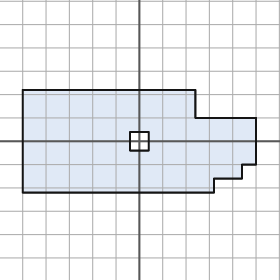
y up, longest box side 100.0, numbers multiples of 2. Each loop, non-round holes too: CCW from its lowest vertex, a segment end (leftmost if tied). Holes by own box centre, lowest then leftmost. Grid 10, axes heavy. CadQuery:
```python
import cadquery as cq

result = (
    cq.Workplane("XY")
    .moveTo(-50.0, -22.0)
    .lineTo(32.0, -22.0)
    .lineTo(32.0, -16.0)
    .lineTo(44.0, -16.0)
    .lineTo(44.0, -10.0)
    .lineTo(50.0, -10.0)
    .lineTo(50.0, 10.0)
    .lineTo(24.0, 10.0)
    .lineTo(24.0, 22.0)
    .lineTo(-50.0, 22.0)
    .close()
    .moveTo(-4.0, -4.0)
    .lineTo(4.0, -4.0)
    .lineTo(4.0, 4.0)
    .lineTo(-4.0, 4.0)
    .close()
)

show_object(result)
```